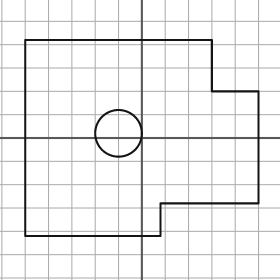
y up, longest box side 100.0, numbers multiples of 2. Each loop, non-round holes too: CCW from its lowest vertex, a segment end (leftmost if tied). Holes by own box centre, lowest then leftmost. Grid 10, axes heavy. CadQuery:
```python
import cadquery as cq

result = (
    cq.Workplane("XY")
    .moveTo(-50.0, -42.0)
    .lineTo(8.0, -42.0)
    .lineTo(8.0, -28.0)
    .lineTo(50.0, -28.0)
    .lineTo(50.0, 20.0)
    .lineTo(30.0, 20.0)
    .lineTo(30.0, 42.0)
    .lineTo(-50.0, 42.0)
    .close()
    .moveTo(-10.0, 2.0)
    .circle(10.0)
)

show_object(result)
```